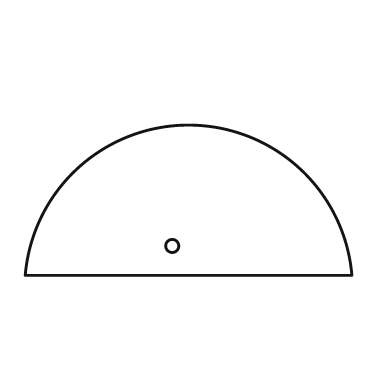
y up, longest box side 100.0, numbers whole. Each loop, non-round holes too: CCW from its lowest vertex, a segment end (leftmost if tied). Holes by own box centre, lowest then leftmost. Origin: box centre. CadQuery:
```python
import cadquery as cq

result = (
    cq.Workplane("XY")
    .moveTo(-50.0, -23.0)
    .lineTo(50.0, -23.0)
    .threePointArc((0.0, 23.0), (-50.0, -23.0))
    .close()
    .moveTo(-5.0, -14.0)
    .circle(2.0)
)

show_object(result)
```